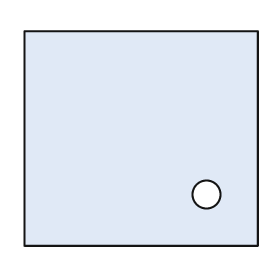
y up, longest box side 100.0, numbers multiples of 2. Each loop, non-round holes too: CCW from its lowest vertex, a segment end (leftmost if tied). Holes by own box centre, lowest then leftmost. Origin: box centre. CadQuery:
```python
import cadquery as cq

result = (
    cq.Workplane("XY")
    .moveTo(-50.0, -46.0)
    .lineTo(50.0, -46.0)
    .lineTo(50.0, 46.0)
    .lineTo(-50.0, 46.0)
    .close()
    .moveTo(28.0, -24.0)
    .circle(6.0)
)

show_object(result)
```